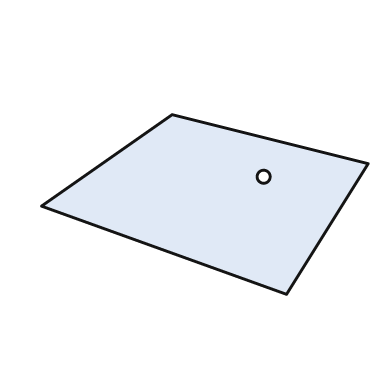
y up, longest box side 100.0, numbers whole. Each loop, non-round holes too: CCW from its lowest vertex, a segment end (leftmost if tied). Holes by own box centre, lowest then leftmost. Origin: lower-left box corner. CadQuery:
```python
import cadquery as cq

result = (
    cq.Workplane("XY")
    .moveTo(75.0, 0.0)
    .lineTo(100.0, 40.0)
    .lineTo(40.0, 55.0)
    .lineTo(0.0, 27.0)
    .close()
    .moveTo(68.0, 36.0)
    .circle(2.0)
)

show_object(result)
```